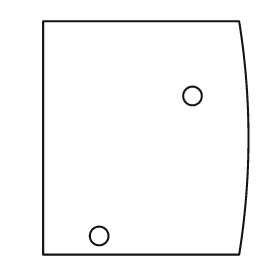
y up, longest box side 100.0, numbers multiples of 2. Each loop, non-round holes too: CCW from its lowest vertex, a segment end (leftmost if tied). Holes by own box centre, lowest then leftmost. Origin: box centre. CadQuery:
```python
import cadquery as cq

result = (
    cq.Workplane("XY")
    .moveTo(-44.0, -50.0)
    .lineTo(40.0, -50.0)
    .threePointArc((44.0, 0.0), (40.0, 50.0))
    .lineTo(-44.0, 50.0)
    .close()
    .moveTo(-20.0, -42.0)
    .circle(4.0)
    .moveTo(20.0, 18.0)
    .circle(4.0)
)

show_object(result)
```